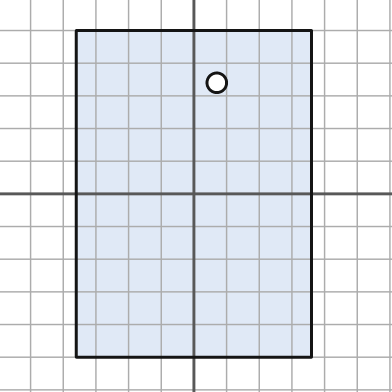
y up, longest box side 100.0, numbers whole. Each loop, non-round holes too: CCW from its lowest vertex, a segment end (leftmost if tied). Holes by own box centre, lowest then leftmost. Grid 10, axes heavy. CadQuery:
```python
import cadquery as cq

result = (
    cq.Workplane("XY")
    .moveTo(-36.0, -50.0)
    .lineTo(36.0, -50.0)
    .lineTo(36.0, 50.0)
    .lineTo(-36.0, 50.0)
    .close()
    .moveTo(7.0, 34.0)
    .circle(3.0)
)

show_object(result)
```